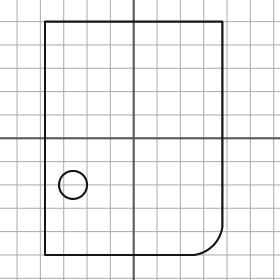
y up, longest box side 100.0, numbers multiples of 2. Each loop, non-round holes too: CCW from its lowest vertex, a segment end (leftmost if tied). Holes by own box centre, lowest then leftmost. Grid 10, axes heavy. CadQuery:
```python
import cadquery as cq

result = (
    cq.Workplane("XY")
    .moveTo(-38.0, -50.0)
    .lineTo(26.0, -50.0)
    .threePointArc((34.0, -46.0), (38.0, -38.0))
    .lineTo(38.0, 50.0)
    .lineTo(-38.0, 50.0)
    .close()
    .moveTo(-26.0, -20.0)
    .circle(6.0)
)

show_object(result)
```